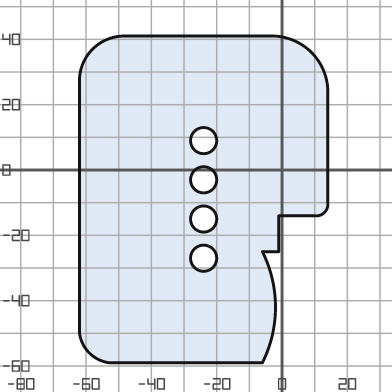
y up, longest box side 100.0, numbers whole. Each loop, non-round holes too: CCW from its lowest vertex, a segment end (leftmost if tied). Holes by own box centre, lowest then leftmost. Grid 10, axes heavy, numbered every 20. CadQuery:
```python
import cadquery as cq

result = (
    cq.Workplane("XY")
    .moveTo(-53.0, -59.0)
    .lineTo(-6.0, -59.0)
    .threePointArc((-2.0, -42.0), (-6.0, -25.0))
    .lineTo(-1.0, -25.0)
    .lineTo(-1.0, -14.0)
    .lineTo(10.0, -14.0)
    .threePointArc((13.0, -13.0), (14.0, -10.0))
    .lineTo(14.0, 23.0)
    .threePointArc((9.0, 36.0), (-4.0, 41.0))
    .lineTo(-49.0, 41.0)
    .threePointArc((-58.0, 37.0), (-62.0, 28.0))
    .lineTo(-62.0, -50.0)
    .threePointArc((-59.0, -56.0), (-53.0, -59.0))
    .close()
    .moveTo(-24.0, -27.0)
    .circle(4.0)
    .moveTo(-24.0, -15.0)
    .circle(4.0)
    .moveTo(-24.0, -3.0)
    .circle(4.0)
    .moveTo(-24.0, 9.0)
    .circle(4.0)
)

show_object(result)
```